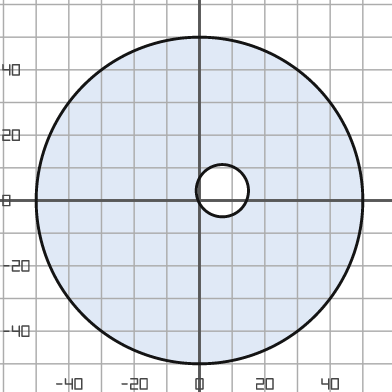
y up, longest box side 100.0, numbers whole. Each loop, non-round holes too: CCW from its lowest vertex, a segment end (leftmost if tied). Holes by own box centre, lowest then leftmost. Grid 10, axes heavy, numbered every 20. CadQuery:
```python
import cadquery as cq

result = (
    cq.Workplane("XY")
    .moveTo(0.0, 0.0)
    .circle(50.0)
    .moveTo(7.0, 3.0)
    .circle(8.0)
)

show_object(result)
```